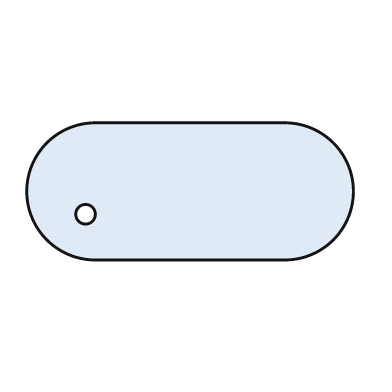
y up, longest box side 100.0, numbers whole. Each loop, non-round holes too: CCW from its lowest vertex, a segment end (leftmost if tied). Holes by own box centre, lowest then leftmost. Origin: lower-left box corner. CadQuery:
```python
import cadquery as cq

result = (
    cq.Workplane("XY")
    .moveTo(21.0, 0.0)
    .lineTo(79.0, 0.0)
    .threePointArc((100.0, 21.0), (79.0, 42.0))
    .lineTo(21.0, 42.0)
    .threePointArc((0.0, 21.0), (21.0, 0.0))
    .close()
    .moveTo(18.0, 14.0)
    .circle(3.0)
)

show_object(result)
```